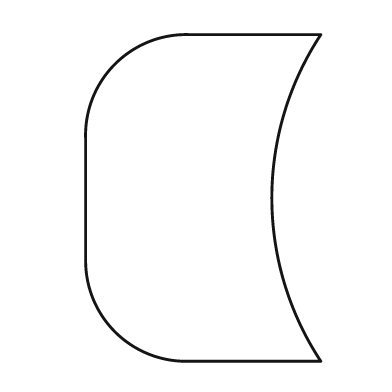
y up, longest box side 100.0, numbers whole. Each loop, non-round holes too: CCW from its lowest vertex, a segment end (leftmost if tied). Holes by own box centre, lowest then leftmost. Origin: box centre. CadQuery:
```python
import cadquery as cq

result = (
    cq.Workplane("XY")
    .moveTo(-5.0, -50.0)
    .lineTo(36.0, -50.0)
    .threePointArc((21.0, 0.0), (36.0, 50.0))
    .lineTo(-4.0, 50.0)
    .threePointArc((-27.0, 41.0), (-36.0, 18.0))
    .lineTo(-36.0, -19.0)
    .threePointArc((-27.0, -41.0), (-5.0, -50.0))
    .close()
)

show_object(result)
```